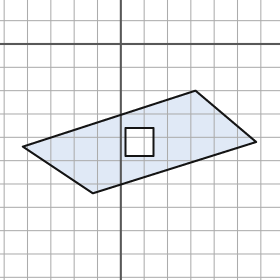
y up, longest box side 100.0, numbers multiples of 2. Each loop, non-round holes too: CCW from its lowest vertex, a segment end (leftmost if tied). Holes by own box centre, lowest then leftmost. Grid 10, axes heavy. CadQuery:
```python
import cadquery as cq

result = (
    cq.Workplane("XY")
    .moveTo(-12.0, -64.0)
    .lineTo(58.0, -42.0)
    .lineTo(32.0, -20.0)
    .lineTo(-42.0, -44.0)
    .close()
    .moveTo(2.0, -48.0)
    .lineTo(14.0, -48.0)
    .lineTo(14.0, -36.0)
    .lineTo(2.0, -36.0)
    .close()
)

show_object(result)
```